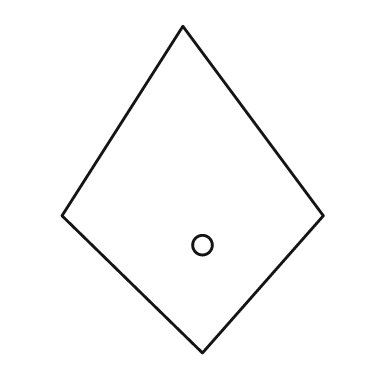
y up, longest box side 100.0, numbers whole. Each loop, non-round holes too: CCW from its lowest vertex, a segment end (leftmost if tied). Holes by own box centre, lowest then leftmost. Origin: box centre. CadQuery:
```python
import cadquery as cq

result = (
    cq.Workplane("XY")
    .moveTo(3.0, -50.0)
    .lineTo(40.0, -8.0)
    .lineTo(-3.0, 50.0)
    .lineTo(-40.0, -8.0)
    .close()
    .moveTo(3.0, -17.0)
    .circle(3.0)
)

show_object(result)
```